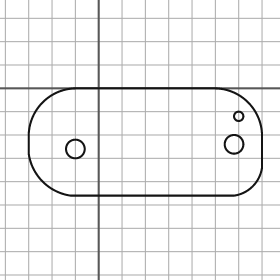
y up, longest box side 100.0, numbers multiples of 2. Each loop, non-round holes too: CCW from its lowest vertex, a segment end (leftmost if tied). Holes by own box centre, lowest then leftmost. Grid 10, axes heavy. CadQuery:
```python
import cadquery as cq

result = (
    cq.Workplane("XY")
    .moveTo(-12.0, -46.0)
    .lineTo(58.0, -46.0)
    .threePointArc((66.0, -42.0), (70.0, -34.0))
    .lineTo(70.0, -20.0)
    .threePointArc((64.0, -6.0), (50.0, 0.0))
    .lineTo(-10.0, 0.0)
    .threePointArc((-24.0, -6.0), (-30.0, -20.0))
    .lineTo(-30.0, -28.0)
    .threePointArc((-24.0, -40.0), (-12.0, -46.0))
    .close()
    .moveTo(-10.0, -26.0)
    .circle(4.0)
    .moveTo(58.0, -24.0)
    .circle(4.0)
    .moveTo(60.0, -12.0)
    .circle(2.0)
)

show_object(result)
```